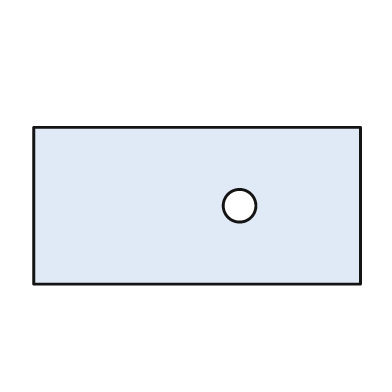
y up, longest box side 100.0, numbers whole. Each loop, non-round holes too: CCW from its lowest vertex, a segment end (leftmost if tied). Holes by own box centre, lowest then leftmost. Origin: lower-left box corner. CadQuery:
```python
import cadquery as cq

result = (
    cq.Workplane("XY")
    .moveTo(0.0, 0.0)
    .lineTo(100.0, 0.0)
    .lineTo(100.0, 48.0)
    .lineTo(0.0, 48.0)
    .close()
    .moveTo(63.0, 24.0)
    .circle(5.0)
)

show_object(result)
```